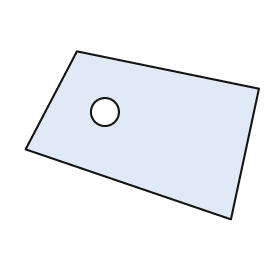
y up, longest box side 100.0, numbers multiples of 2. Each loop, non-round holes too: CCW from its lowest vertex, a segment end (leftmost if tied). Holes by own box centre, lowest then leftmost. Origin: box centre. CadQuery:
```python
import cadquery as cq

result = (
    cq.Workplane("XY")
    .moveTo(38.0, -36.0)
    .lineTo(50.0, 20.0)
    .lineTo(-28.0, 36.0)
    .lineTo(-50.0, -6.0)
    .close()
    .moveTo(-16.0, 10.0)
    .circle(6.0)
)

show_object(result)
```